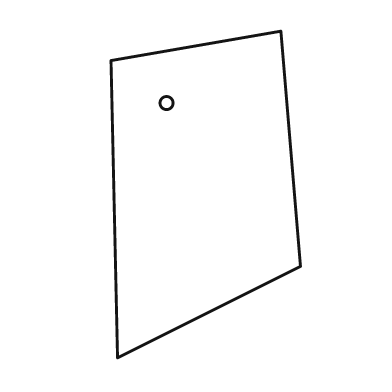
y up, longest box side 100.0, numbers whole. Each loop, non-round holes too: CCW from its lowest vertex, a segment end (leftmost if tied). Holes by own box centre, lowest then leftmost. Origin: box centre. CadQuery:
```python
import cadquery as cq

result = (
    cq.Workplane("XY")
    .moveTo(-27.0, -50.0)
    .lineTo(29.0, -22.0)
    .lineTo(23.0, 50.0)
    .lineTo(-29.0, 41.0)
    .close()
    .moveTo(-12.0, 28.0)
    .circle(2.0)
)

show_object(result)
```